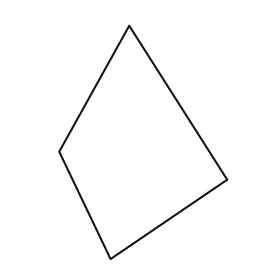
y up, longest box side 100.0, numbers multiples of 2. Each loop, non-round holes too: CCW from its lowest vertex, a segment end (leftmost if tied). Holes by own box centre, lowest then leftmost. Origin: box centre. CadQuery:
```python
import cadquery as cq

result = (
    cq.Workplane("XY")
    .moveTo(-14.0, -50.0)
    .lineTo(36.0, -16.0)
    .lineTo(-6.0, 50.0)
    .lineTo(-36.0, -4.0)
    .close()
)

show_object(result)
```